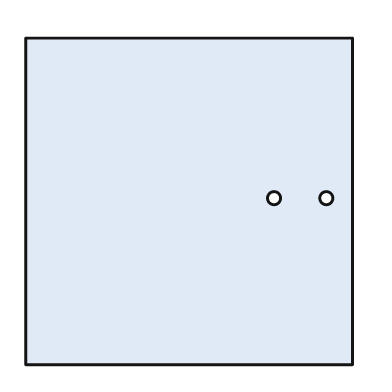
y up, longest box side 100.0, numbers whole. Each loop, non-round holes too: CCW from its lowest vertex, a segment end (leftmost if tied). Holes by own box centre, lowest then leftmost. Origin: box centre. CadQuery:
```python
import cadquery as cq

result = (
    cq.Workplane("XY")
    .moveTo(-50.0, -50.0)
    .lineTo(50.0, -50.0)
    .lineTo(50.0, 50.0)
    .lineTo(-50.0, 50.0)
    .close()
    .moveTo(26.0, 1.0)
    .circle(2.0)
    .moveTo(42.0, 1.0)
    .circle(2.0)
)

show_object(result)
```